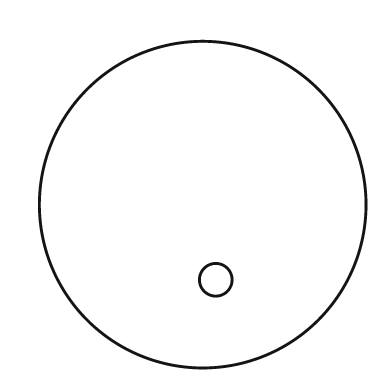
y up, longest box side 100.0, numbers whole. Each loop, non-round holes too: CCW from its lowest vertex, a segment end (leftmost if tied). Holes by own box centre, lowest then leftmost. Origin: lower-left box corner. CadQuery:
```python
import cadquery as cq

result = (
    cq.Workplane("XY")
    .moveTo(50.0, 50.0)
    .circle(50.0)
    .moveTo(54.0, 27.0)
    .circle(5.0)
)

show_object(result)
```